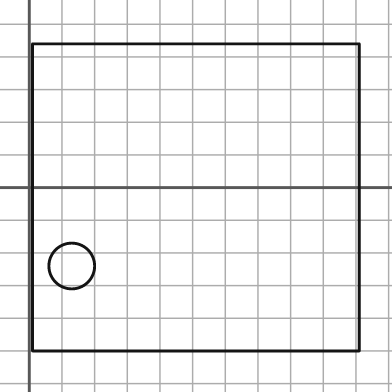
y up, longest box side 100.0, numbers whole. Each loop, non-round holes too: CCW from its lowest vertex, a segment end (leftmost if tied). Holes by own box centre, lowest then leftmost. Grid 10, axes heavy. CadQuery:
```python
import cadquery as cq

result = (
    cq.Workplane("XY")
    .moveTo(1.0, -50.0)
    .lineTo(101.0, -50.0)
    .lineTo(101.0, 44.0)
    .lineTo(1.0, 44.0)
    .close()
    .moveTo(13.0, -24.0)
    .circle(7.0)
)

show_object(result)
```